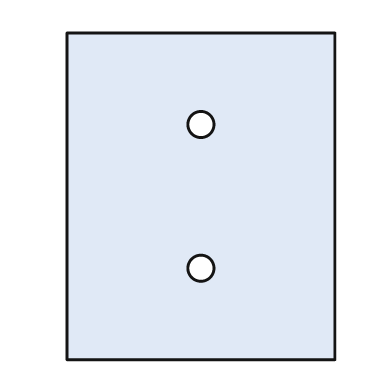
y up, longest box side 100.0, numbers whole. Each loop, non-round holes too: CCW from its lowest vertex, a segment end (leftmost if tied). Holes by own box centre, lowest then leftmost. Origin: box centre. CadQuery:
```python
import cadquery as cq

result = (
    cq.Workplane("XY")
    .moveTo(-41.0, -50.0)
    .lineTo(41.0, -50.0)
    .lineTo(41.0, 50.0)
    .lineTo(-41.0, 50.0)
    .close()
    .moveTo(0.0, -22.0)
    .circle(4.0)
    .moveTo(0.0, 22.0)
    .circle(4.0)
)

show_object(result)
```